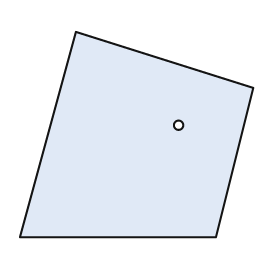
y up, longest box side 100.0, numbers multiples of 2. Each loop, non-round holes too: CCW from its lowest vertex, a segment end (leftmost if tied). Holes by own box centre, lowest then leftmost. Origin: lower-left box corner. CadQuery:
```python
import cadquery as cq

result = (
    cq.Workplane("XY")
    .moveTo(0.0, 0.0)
    .lineTo(84.0, 0.0)
    .lineTo(100.0, 64.0)
    .lineTo(24.0, 88.0)
    .close()
    .moveTo(68.0, 48.0)
    .circle(2.0)
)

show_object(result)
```